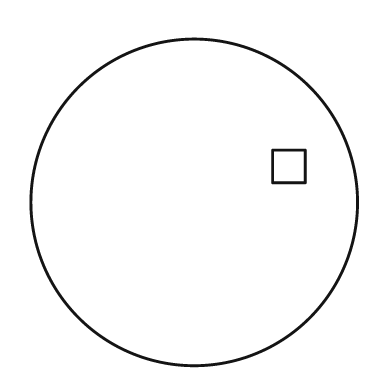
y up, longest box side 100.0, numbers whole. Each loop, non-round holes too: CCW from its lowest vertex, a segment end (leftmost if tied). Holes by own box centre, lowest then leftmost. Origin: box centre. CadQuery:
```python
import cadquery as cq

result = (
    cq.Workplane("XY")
    .moveTo(0.0, 0.0)
    .circle(50.0)
    .moveTo(24.0, 6.0)
    .lineTo(34.0, 6.0)
    .lineTo(34.0, 16.0)
    .lineTo(24.0, 16.0)
    .close()
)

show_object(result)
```